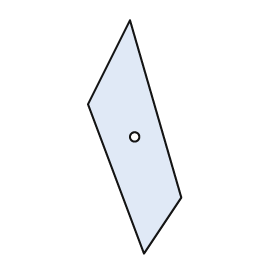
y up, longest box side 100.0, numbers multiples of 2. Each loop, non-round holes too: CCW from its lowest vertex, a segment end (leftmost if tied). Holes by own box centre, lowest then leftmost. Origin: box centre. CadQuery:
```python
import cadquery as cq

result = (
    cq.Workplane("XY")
    .moveTo(4.0, -50.0)
    .lineTo(20.0, -26.0)
    .lineTo(-2.0, 50.0)
    .lineTo(-20.0, 14.0)
    .close()
    .moveTo(0.0, 0.0)
    .circle(2.0)
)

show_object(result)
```